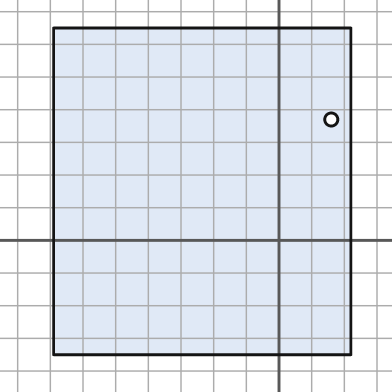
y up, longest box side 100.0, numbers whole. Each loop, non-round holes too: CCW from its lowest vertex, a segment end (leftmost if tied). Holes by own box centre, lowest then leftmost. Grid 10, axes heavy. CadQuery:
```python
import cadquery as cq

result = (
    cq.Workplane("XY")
    .moveTo(-69.0, -35.0)
    .lineTo(22.0, -35.0)
    .lineTo(22.0, 65.0)
    .lineTo(-69.0, 65.0)
    .close()
    .moveTo(16.0, 37.0)
    .circle(2.0)
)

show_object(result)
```